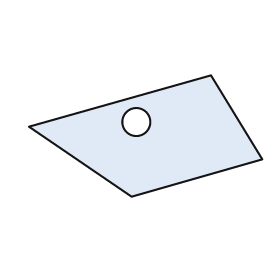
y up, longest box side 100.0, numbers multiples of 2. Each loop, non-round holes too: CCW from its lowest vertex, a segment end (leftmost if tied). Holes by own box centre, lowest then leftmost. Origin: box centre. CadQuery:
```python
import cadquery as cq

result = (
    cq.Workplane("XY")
    .moveTo(-6.0, -26.0)
    .lineTo(50.0, -10.0)
    .lineTo(28.0, 26.0)
    .lineTo(-50.0, 4.0)
    .close()
    .moveTo(-4.0, 6.0)
    .circle(6.0)
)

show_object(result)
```